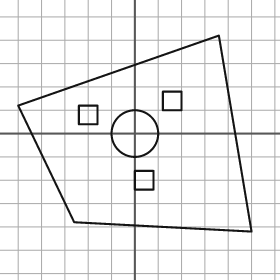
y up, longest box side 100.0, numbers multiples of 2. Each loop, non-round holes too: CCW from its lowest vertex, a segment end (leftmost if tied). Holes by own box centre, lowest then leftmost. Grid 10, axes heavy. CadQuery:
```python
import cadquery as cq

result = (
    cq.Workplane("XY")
    .moveTo(50.0, -42.0)
    .lineTo(36.0, 42.0)
    .lineTo(-50.0, 12.0)
    .lineTo(-26.0, -38.0)
    .close()
    .moveTo(0.0, -24.0)
    .lineTo(8.0, -24.0)
    .lineTo(8.0, -16.0)
    .lineTo(0.0, -16.0)
    .close()
    .moveTo(0.0, 0.0)
    .circle(10.0)
    .moveTo(-24.0, 4.0)
    .lineTo(-16.0, 4.0)
    .lineTo(-16.0, 12.0)
    .lineTo(-24.0, 12.0)
    .close()
    .moveTo(12.0, 10.0)
    .lineTo(20.0, 10.0)
    .lineTo(20.0, 18.0)
    .lineTo(12.0, 18.0)
    .close()
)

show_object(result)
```